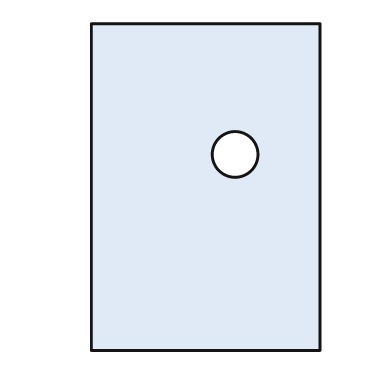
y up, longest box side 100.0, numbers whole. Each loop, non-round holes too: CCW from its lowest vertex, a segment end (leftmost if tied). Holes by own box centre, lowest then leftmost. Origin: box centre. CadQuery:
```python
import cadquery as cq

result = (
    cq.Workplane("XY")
    .moveTo(-35.0, -50.0)
    .lineTo(35.0, -50.0)
    .lineTo(35.0, 50.0)
    .lineTo(-35.0, 50.0)
    .close()
    .moveTo(9.0, 10.0)
    .circle(7.0)
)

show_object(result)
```